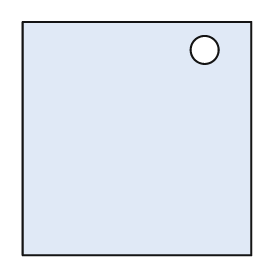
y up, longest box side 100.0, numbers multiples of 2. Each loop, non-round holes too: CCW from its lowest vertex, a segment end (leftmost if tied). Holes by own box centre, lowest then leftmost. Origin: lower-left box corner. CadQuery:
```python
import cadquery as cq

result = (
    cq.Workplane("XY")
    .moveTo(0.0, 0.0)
    .lineTo(98.0, 0.0)
    .lineTo(98.0, 100.0)
    .lineTo(0.0, 100.0)
    .close()
    .moveTo(78.0, 88.0)
    .circle(6.0)
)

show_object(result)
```